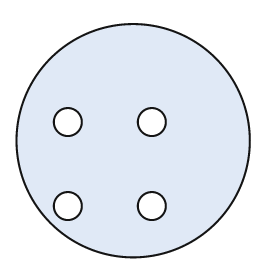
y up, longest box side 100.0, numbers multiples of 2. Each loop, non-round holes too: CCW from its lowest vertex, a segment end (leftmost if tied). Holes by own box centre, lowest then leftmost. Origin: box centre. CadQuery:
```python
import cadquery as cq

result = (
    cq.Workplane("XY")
    .moveTo(0.0, 0.0)
    .circle(50.0)
    .moveTo(-28.0, -28.0)
    .circle(6.0)
    .moveTo(8.0, -28.0)
    .circle(6.0)
    .moveTo(-28.0, 8.0)
    .circle(6.0)
    .moveTo(8.0, 8.0)
    .circle(6.0)
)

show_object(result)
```